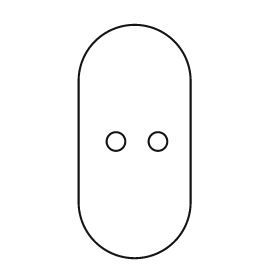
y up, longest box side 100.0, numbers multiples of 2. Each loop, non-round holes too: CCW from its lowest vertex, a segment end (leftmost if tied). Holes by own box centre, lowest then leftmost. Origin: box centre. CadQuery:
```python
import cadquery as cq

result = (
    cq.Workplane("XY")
    .moveTo(-24.0, -26.0)
    .threePointArc((0.0, -50.0), (24.0, -26.0))
    .lineTo(24.0, 26.0)
    .threePointArc((0.0, 50.0), (-24.0, 26.0))
    .close()
    .moveTo(-8.0, 0.0)
    .circle(4.0)
    .moveTo(10.0, 0.0)
    .circle(4.0)
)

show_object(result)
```